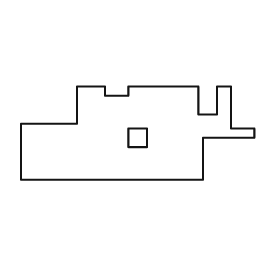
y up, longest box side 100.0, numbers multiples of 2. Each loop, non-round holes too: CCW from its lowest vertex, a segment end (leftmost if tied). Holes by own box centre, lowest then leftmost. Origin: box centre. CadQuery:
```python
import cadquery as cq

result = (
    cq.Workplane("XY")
    .moveTo(-50.0, -20.0)
    .lineTo(28.0, -20.0)
    .lineTo(28.0, -2.0)
    .lineTo(50.0, -2.0)
    .lineTo(50.0, 2.0)
    .lineTo(40.0, 2.0)
    .lineTo(40.0, 20.0)
    .lineTo(34.0, 20.0)
    .lineTo(34.0, 8.0)
    .lineTo(26.0, 8.0)
    .lineTo(26.0, 20.0)
    .lineTo(-4.0, 20.0)
    .lineTo(-4.0, 16.0)
    .lineTo(-14.0, 16.0)
    .lineTo(-14.0, 20.0)
    .lineTo(-26.0, 20.0)
    .lineTo(-26.0, 4.0)
    .lineTo(-50.0, 4.0)
    .close()
    .moveTo(-4.0, -6.0)
    .lineTo(4.0, -6.0)
    .lineTo(4.0, 2.0)
    .lineTo(-4.0, 2.0)
    .close()
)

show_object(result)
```